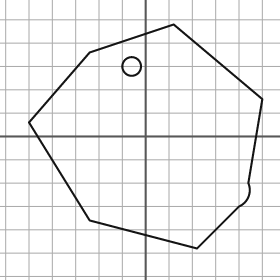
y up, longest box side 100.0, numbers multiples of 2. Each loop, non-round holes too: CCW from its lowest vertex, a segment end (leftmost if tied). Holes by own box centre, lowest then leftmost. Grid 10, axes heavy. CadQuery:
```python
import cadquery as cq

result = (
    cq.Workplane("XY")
    .moveTo(22.0, -48.0)
    .lineTo(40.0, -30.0)
    .threePointArc((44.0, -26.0), (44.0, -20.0))
    .lineTo(50.0, 16.0)
    .lineTo(12.0, 48.0)
    .lineTo(-24.0, 36.0)
    .lineTo(-50.0, 6.0)
    .lineTo(-24.0, -36.0)
    .close()
    .moveTo(-6.0, 30.0)
    .circle(4.0)
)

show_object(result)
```